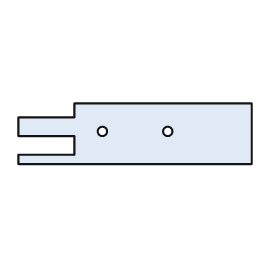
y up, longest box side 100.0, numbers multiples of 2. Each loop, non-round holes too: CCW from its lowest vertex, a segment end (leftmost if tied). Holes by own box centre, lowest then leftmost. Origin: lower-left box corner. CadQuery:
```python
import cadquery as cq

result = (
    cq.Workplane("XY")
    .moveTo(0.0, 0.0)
    .lineTo(100.0, 0.0)
    .lineTo(100.0, 26.0)
    .lineTo(24.0, 26.0)
    .lineTo(24.0, 20.0)
    .lineTo(0.0, 20.0)
    .lineTo(0.0, 12.0)
    .lineTo(24.0, 12.0)
    .lineTo(24.0, 4.0)
    .lineTo(0.0, 4.0)
    .close()
    .moveTo(36.0, 14.0)
    .circle(2.0)
    .moveTo(64.0, 14.0)
    .circle(2.0)
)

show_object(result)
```